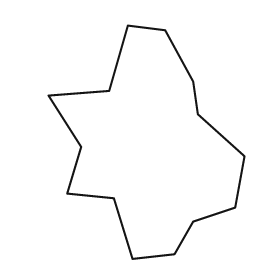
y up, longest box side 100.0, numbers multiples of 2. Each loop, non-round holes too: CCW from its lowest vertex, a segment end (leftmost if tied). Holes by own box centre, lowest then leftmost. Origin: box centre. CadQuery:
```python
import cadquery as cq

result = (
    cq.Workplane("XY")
    .moveTo(-6.0, -50.0)
    .lineTo(12.0, -48.0)
    .lineTo(20.0, -34.0)
    .lineTo(38.0, -28.0)
    .lineTo(42.0, -6.0)
    .lineTo(22.0, 12.0)
    .lineTo(20.0, 26.0)
    .lineTo(8.0, 48.0)
    .lineTo(-8.0, 50.0)
    .lineTo(-16.0, 22.0)
    .lineTo(-42.0, 20.0)
    .lineTo(-28.0, -2.0)
    .lineTo(-34.0, -22.0)
    .lineTo(-14.0, -24.0)
    .close()
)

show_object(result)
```